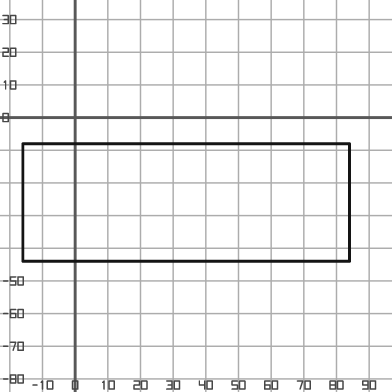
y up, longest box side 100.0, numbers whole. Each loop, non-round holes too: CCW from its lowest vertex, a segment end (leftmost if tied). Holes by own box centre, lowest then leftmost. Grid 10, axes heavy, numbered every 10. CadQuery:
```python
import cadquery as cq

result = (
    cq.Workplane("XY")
    .moveTo(-16.0, -44.0)
    .lineTo(84.0, -44.0)
    .lineTo(84.0, -8.0)
    .lineTo(-16.0, -8.0)
    .close()
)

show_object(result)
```